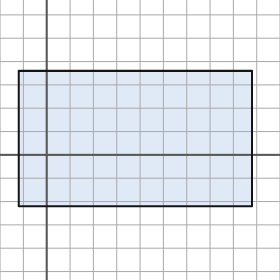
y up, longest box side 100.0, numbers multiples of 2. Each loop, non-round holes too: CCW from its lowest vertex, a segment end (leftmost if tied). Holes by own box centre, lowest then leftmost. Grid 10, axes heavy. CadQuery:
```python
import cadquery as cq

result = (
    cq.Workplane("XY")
    .moveTo(-12.0, -22.0)
    .lineTo(88.0, -22.0)
    .lineTo(88.0, 36.0)
    .lineTo(-12.0, 36.0)
    .close()
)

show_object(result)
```